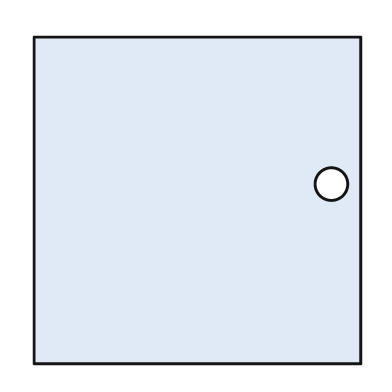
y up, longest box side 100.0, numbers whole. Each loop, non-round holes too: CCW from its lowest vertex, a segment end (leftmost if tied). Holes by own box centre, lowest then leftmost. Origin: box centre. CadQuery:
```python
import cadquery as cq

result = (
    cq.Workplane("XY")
    .moveTo(-50.0, -50.0)
    .lineTo(50.0, -50.0)
    .lineTo(50.0, 50.0)
    .lineTo(-50.0, 50.0)
    .close()
    .moveTo(41.0, 5.0)
    .circle(5.0)
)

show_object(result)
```